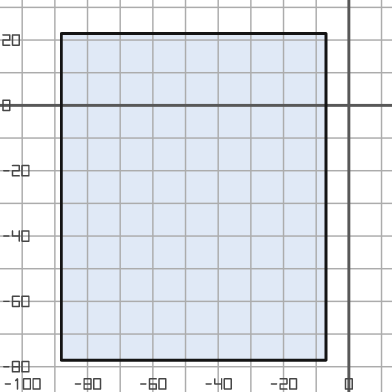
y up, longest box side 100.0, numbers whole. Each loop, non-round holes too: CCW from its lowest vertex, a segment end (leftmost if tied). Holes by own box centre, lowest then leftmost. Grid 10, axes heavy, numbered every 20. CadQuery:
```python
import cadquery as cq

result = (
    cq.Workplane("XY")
    .moveTo(-88.0, -78.0)
    .lineTo(-7.0, -78.0)
    .lineTo(-7.0, 22.0)
    .lineTo(-88.0, 22.0)
    .close()
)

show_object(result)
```